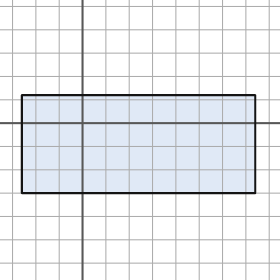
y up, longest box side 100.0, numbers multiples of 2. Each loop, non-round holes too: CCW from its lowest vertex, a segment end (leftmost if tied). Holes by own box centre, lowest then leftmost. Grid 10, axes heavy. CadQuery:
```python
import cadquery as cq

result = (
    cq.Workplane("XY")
    .moveTo(-26.0, -30.0)
    .lineTo(74.0, -30.0)
    .lineTo(74.0, 12.0)
    .lineTo(-26.0, 12.0)
    .close()
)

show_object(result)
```